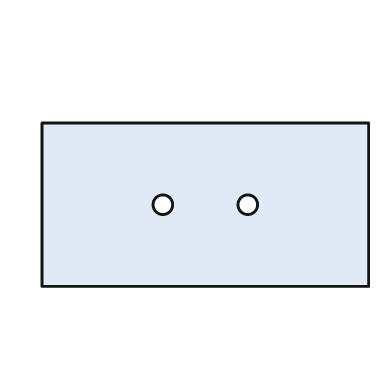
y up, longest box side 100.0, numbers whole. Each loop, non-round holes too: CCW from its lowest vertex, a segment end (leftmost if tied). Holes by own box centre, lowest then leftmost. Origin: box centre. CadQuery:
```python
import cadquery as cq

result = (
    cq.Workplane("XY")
    .moveTo(-50.0, -25.0)
    .lineTo(50.0, -25.0)
    .lineTo(50.0, 25.0)
    .lineTo(-50.0, 25.0)
    .close()
    .moveTo(-13.0, 0.0)
    .circle(3.0)
    .moveTo(13.0, 0.0)
    .circle(3.0)
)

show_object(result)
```